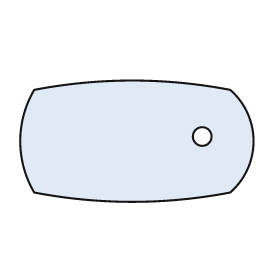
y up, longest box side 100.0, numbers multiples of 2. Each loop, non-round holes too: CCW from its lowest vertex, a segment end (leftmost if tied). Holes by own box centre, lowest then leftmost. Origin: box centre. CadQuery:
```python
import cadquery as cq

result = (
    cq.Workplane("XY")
    .moveTo(-44.0, -22.0)
    .threePointArc((-2.0, -26.0), (40.0, -22.0))
    .threePointArc((50.0, 0.0), (40.0, 22.0))
    .threePointArc((-2.0, 26.0), (-44.0, 22.0))
    .threePointArc((-50.0, 0.0), (-44.0, -22.0))
    .close()
    .moveTo(28.0, 2.0)
    .circle(4.0)
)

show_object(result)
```